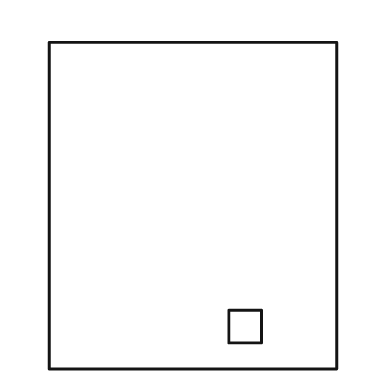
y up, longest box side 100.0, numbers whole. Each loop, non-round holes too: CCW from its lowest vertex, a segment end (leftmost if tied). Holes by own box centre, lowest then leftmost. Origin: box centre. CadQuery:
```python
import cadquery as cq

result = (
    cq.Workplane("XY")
    .moveTo(-44.0, -50.0)
    .lineTo(44.0, -50.0)
    .lineTo(44.0, 50.0)
    .lineTo(-44.0, 50.0)
    .close()
    .moveTo(11.0, -42.0)
    .lineTo(21.0, -42.0)
    .lineTo(21.0, -32.0)
    .lineTo(11.0, -32.0)
    .close()
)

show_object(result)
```